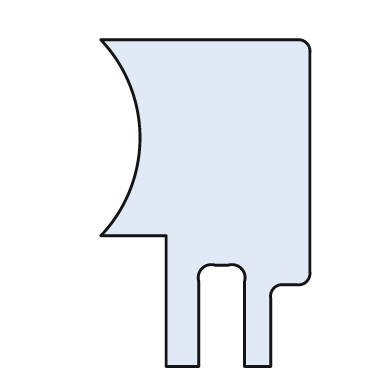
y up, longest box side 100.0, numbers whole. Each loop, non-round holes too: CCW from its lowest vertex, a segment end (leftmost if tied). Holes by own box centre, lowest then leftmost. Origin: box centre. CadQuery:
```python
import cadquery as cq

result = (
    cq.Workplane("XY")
    .moveTo(-12.0, -50.0)
    .lineTo(-2.0, -50.0)
    .lineTo(-2.0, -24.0)
    .threePointArc((-1.0, -20.0), (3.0, -19.0))
    .lineTo(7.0, -19.0)
    .threePointArc((11.0, -20.0), (12.0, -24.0))
    .lineTo(12.0, -50.0)
    .lineTo(20.0, -50.0)
    .lineTo(20.0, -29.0)
    .threePointArc((21.0, -26.0), (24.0, -25.0))
    .lineTo(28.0, -25.0)
    .threePointArc((31.0, -24.0), (32.0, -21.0))
    .lineTo(32.0, 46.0)
    .threePointArc((31.0, 49.0), (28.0, 50.0))
    .lineTo(-32.0, 50.0)
    .threePointArc((-20.0, 20.0), (-32.0, -10.0))
    .lineTo(-12.0, -10.0)
    .close()
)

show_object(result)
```